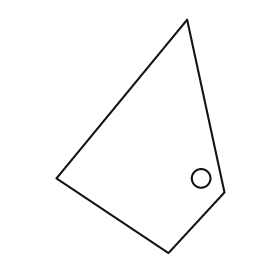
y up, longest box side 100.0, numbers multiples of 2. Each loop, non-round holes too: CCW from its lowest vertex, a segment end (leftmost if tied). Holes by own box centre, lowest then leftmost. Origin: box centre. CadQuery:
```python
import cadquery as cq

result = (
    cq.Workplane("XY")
    .moveTo(12.0, -50.0)
    .lineTo(36.0, -24.0)
    .lineTo(20.0, 50.0)
    .lineTo(-36.0, -18.0)
    .close()
    .moveTo(26.0, -18.0)
    .circle(4.0)
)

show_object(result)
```